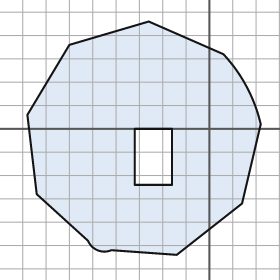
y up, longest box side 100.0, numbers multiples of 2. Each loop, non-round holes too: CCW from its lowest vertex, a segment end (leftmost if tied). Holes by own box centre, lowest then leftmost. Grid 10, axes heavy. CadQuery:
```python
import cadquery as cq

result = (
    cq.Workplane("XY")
    .moveTo(-14.0, -54.0)
    .lineTo(14.0, -32.0)
    .lineTo(22.0, 2.0)
    .threePointArc((16.0, 18.0), (6.0, 32.0))
    .lineTo(-26.0, 46.0)
    .lineTo(-60.0, 36.0)
    .lineTo(-78.0, 6.0)
    .lineTo(-74.0, -28.0)
    .lineTo(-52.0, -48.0)
    .threePointArc((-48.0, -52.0), (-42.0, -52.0))
    .close()
    .moveTo(-32.0, -24.0)
    .lineTo(-16.0, -24.0)
    .lineTo(-16.0, 0.0)
    .lineTo(-32.0, 0.0)
    .close()
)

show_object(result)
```